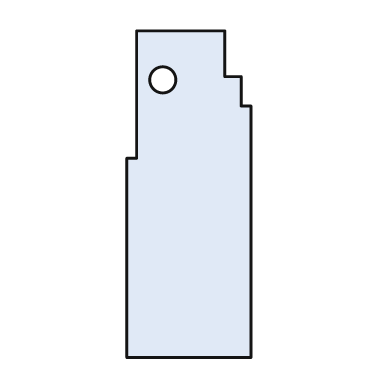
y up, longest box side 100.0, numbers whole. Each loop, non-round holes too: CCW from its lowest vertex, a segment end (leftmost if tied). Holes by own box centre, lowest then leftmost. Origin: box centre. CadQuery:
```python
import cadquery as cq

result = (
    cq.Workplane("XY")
    .moveTo(-19.0, -50.0)
    .lineTo(19.0, -50.0)
    .lineTo(19.0, 27.0)
    .lineTo(16.0, 27.0)
    .lineTo(16.0, 36.0)
    .lineTo(11.0, 36.0)
    .lineTo(11.0, 50.0)
    .lineTo(-16.0, 50.0)
    .lineTo(-16.0, 11.0)
    .lineTo(-19.0, 11.0)
    .close()
    .moveTo(-8.0, 35.0)
    .circle(4.0)
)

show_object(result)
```